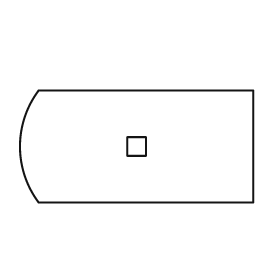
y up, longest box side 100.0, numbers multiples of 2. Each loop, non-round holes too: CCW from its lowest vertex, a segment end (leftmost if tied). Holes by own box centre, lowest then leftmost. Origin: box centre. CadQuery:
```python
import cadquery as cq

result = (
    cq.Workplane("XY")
    .moveTo(-42.0, -24.0)
    .lineTo(50.0, -24.0)
    .lineTo(50.0, 24.0)
    .lineTo(-42.0, 24.0)
    .threePointArc((-50.0, 0.0), (-42.0, -24.0))
    .close()
    .moveTo(-4.0, -4.0)
    .lineTo(4.0, -4.0)
    .lineTo(4.0, 4.0)
    .lineTo(-4.0, 4.0)
    .close()
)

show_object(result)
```